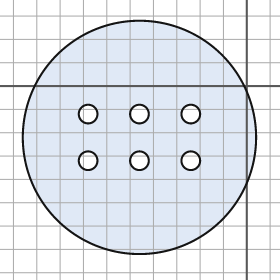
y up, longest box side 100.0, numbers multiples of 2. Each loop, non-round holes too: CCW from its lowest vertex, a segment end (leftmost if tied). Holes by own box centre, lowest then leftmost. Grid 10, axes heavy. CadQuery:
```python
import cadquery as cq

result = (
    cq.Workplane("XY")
    .moveTo(-46.0, -22.0)
    .circle(50.0)
    .moveTo(-68.0, -32.0)
    .circle(4.0)
    .moveTo(-46.0, -32.0)
    .circle(4.0)
    .moveTo(-24.0, -32.0)
    .circle(4.0)
    .moveTo(-68.0, -12.0)
    .circle(4.0)
    .moveTo(-46.0, -12.0)
    .circle(4.0)
    .moveTo(-24.0, -12.0)
    .circle(4.0)
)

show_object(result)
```